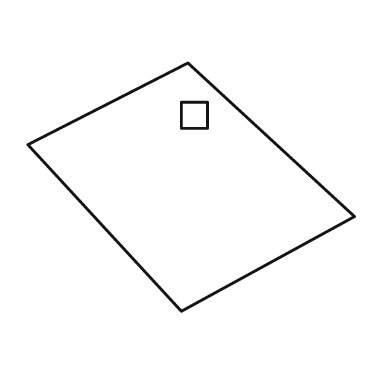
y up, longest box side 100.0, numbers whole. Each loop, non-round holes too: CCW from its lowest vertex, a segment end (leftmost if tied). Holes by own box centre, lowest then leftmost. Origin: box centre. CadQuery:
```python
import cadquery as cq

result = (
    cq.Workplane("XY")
    .moveTo(-3.0, -38.0)
    .lineTo(50.0, -9.0)
    .lineTo(-1.0, 38.0)
    .lineTo(-50.0, 13.0)
    .close()
    .moveTo(-3.0, 18.0)
    .lineTo(5.0, 18.0)
    .lineTo(5.0, 26.0)
    .lineTo(-3.0, 26.0)
    .close()
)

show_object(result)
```